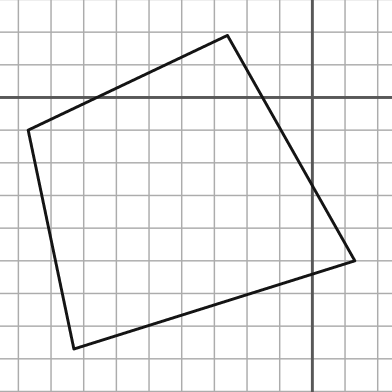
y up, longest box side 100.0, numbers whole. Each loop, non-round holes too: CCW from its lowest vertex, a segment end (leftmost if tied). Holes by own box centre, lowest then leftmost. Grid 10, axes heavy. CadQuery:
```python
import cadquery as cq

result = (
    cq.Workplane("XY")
    .moveTo(-73.0, -77.0)
    .lineTo(13.0, -50.0)
    .lineTo(-26.0, 19.0)
    .lineTo(-87.0, -10.0)
    .close()
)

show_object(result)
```